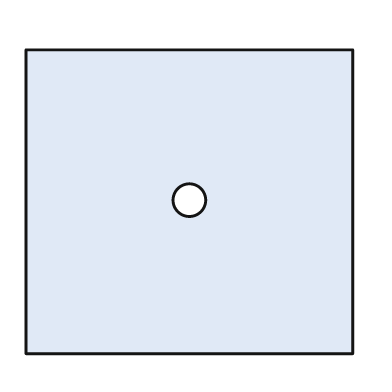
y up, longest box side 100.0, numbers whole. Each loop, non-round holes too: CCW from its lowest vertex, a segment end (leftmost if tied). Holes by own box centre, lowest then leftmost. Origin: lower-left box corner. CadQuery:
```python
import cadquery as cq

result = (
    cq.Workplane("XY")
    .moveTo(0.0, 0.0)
    .lineTo(100.0, 0.0)
    .lineTo(100.0, 93.0)
    .lineTo(0.0, 93.0)
    .close()
    .moveTo(50.0, 47.0)
    .circle(5.0)
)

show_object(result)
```